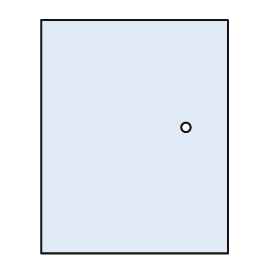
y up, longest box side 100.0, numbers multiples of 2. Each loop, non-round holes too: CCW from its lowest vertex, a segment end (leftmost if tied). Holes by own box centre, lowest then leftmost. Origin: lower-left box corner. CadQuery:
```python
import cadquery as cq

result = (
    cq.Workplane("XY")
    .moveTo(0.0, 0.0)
    .lineTo(80.0, 0.0)
    .lineTo(80.0, 100.0)
    .lineTo(0.0, 100.0)
    .close()
    .moveTo(62.0, 54.0)
    .circle(2.0)
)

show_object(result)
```